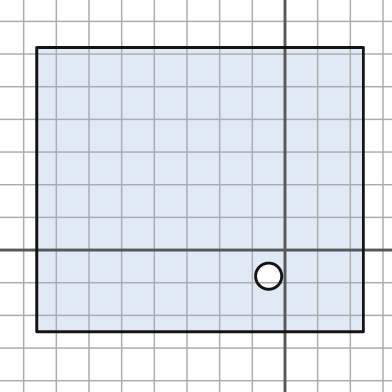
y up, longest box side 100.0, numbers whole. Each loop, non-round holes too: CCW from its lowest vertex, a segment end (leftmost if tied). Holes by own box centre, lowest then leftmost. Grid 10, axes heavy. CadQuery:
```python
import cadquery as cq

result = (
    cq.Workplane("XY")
    .moveTo(-76.0, -25.0)
    .lineTo(24.0, -25.0)
    .lineTo(24.0, 62.0)
    .lineTo(-76.0, 62.0)
    .close()
    .moveTo(-5.0, -8.0)
    .circle(4.0)
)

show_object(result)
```